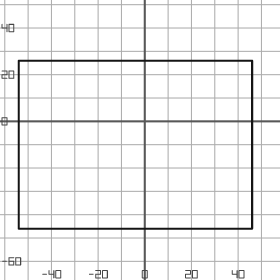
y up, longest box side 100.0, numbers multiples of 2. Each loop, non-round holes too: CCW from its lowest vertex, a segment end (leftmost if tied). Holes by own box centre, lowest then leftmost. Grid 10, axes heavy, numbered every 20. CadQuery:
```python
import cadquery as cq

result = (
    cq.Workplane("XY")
    .moveTo(-54.0, -46.0)
    .lineTo(46.0, -46.0)
    .lineTo(46.0, 26.0)
    .lineTo(-54.0, 26.0)
    .close()
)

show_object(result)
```